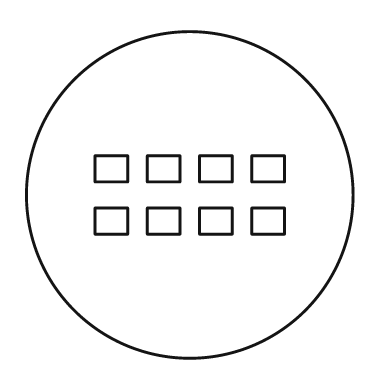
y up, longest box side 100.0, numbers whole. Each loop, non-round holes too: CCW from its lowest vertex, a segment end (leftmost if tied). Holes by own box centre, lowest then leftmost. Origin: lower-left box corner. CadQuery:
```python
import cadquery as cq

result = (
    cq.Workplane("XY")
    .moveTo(50.0, 50.0)
    .circle(50.0)
    .moveTo(21.0, 38.0)
    .lineTo(31.0, 38.0)
    .lineTo(31.0, 46.0)
    .lineTo(21.0, 46.0)
    .close()
    .moveTo(37.0, 38.0)
    .lineTo(47.0, 38.0)
    .lineTo(47.0, 46.0)
    .lineTo(37.0, 46.0)
    .close()
    .moveTo(53.0, 38.0)
    .lineTo(63.0, 38.0)
    .lineTo(63.0, 46.0)
    .lineTo(53.0, 46.0)
    .close()
    .moveTo(69.0, 38.0)
    .lineTo(79.0, 38.0)
    .lineTo(79.0, 46.0)
    .lineTo(69.0, 46.0)
    .close()
    .moveTo(21.0, 54.0)
    .lineTo(31.0, 54.0)
    .lineTo(31.0, 62.0)
    .lineTo(21.0, 62.0)
    .close()
    .moveTo(37.0, 54.0)
    .lineTo(47.0, 54.0)
    .lineTo(47.0, 62.0)
    .lineTo(37.0, 62.0)
    .close()
    .moveTo(53.0, 54.0)
    .lineTo(63.0, 54.0)
    .lineTo(63.0, 62.0)
    .lineTo(53.0, 62.0)
    .close()
    .moveTo(69.0, 54.0)
    .lineTo(79.0, 54.0)
    .lineTo(79.0, 62.0)
    .lineTo(69.0, 62.0)
    .close()
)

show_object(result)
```